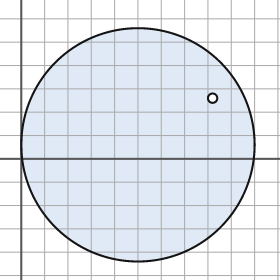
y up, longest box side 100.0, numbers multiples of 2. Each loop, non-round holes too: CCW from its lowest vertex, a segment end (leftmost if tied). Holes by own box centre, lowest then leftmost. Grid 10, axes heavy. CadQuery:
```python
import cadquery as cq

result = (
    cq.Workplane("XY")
    .moveTo(50.0, 6.0)
    .circle(50.0)
    .moveTo(82.0, 26.0)
    .circle(2.0)
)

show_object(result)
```